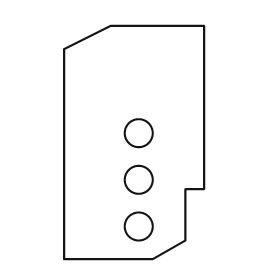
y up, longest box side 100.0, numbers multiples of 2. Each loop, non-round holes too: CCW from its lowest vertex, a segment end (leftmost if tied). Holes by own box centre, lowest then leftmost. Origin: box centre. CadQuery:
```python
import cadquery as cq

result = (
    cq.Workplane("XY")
    .moveTo(-30.0, -50.0)
    .lineTo(8.0, -50.0)
    .lineTo(22.0, -42.0)
    .lineTo(22.0, -20.0)
    .lineTo(30.0, -20.0)
    .lineTo(30.0, 50.0)
    .lineTo(-10.0, 50.0)
    .lineTo(-30.0, 40.0)
    .close()
    .moveTo(2.0, -36.0)
    .circle(6.0)
    .moveTo(2.0, -16.0)
    .circle(6.0)
    .moveTo(2.0, 4.0)
    .circle(6.0)
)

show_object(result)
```